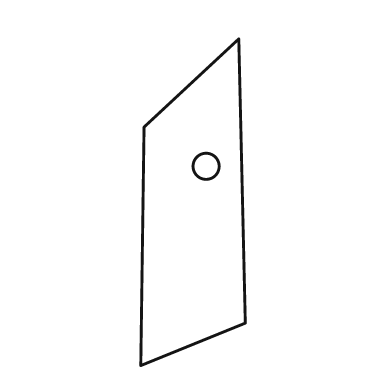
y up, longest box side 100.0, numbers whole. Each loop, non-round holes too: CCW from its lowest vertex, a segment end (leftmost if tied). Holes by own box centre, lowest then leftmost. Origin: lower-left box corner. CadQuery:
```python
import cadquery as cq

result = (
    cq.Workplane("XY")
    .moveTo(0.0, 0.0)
    .lineTo(32.0, 13.0)
    .lineTo(30.0, 100.0)
    .lineTo(1.0, 73.0)
    .close()
    .moveTo(20.0, 61.0)
    .circle(4.0)
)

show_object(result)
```